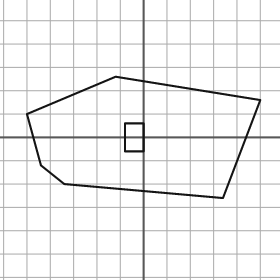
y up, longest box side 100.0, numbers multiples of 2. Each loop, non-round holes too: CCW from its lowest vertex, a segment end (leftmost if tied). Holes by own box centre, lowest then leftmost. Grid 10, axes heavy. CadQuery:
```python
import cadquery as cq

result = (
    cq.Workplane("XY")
    .moveTo(34.0, -26.0)
    .lineTo(50.0, 16.0)
    .lineTo(-12.0, 26.0)
    .lineTo(-50.0, 10.0)
    .lineTo(-44.0, -12.0)
    .lineTo(-34.0, -20.0)
    .close()
    .moveTo(-8.0, -6.0)
    .lineTo(0.0, -6.0)
    .lineTo(0.0, 6.0)
    .lineTo(-8.0, 6.0)
    .close()
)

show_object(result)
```